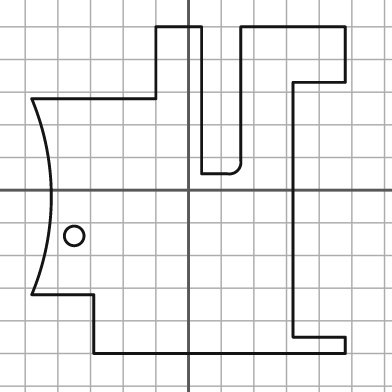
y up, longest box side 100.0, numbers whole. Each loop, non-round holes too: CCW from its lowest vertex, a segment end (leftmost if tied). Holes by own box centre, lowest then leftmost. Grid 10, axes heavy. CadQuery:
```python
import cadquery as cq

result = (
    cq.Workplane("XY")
    .moveTo(-29.0, -50.0)
    .lineTo(48.0, -50.0)
    .lineTo(48.0, -45.0)
    .lineTo(32.0, -45.0)
    .lineTo(32.0, 33.0)
    .lineTo(48.0, 33.0)
    .lineTo(48.0, 50.0)
    .lineTo(16.0, 50.0)
    .lineTo(16.0, 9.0)
    .threePointArc((15.0, 6.0), (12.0, 5.0))
    .lineTo(4.0, 5.0)
    .lineTo(4.0, 50.0)
    .lineTo(-10.0, 50.0)
    .lineTo(-10.0, 28.0)
    .lineTo(-48.0, 28.0)
    .threePointArc((-42.0, -2.0), (-48.0, -32.0))
    .lineTo(-29.0, -32.0)
    .close()
    .moveTo(-35.0, -14.0)
    .circle(3.0)
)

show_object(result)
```